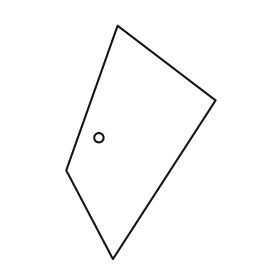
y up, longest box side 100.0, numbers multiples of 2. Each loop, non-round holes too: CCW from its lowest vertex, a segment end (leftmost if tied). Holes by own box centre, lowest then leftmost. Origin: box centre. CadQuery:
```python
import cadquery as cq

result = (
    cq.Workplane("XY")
    .moveTo(-12.0, -50.0)
    .lineTo(32.0, 18.0)
    .lineTo(-10.0, 50.0)
    .lineTo(-32.0, -12.0)
    .close()
    .moveTo(-18.0, 2.0)
    .circle(2.0)
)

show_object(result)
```